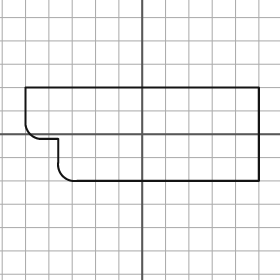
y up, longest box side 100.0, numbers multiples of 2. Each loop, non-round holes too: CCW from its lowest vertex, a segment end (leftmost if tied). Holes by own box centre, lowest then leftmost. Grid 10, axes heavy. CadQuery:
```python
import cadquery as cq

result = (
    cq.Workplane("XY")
    .moveTo(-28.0, -20.0)
    .lineTo(50.0, -20.0)
    .lineTo(50.0, 20.0)
    .lineTo(-50.0, 20.0)
    .lineTo(-50.0, 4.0)
    .threePointArc((-48.0, 0.0), (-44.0, -2.0))
    .lineTo(-36.0, -2.0)
    .lineTo(-36.0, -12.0)
    .threePointArc((-34.0, -18.0), (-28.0, -20.0))
    .close()
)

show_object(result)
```